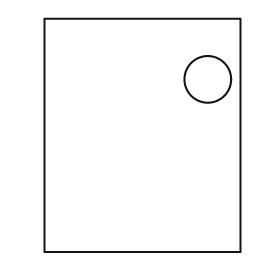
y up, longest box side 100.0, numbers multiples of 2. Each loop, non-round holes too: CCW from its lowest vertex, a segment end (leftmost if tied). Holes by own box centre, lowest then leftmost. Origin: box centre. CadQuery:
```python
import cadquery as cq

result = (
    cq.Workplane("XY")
    .moveTo(-42.0, -50.0)
    .lineTo(42.0, -50.0)
    .lineTo(42.0, 50.0)
    .lineTo(-42.0, 50.0)
    .close()
    .moveTo(28.0, 24.0)
    .circle(10.0)
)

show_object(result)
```